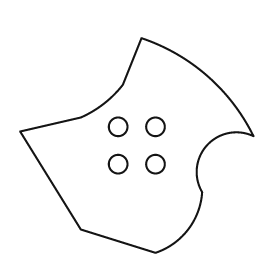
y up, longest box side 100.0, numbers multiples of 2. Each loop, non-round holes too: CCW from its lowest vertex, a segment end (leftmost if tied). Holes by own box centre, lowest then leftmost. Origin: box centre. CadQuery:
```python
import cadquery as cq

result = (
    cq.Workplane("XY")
    .moveTo(8.0, -46.0)
    .threePointArc((22.0, -36.0), (28.0, -20.0))
    .threePointArc((30.0, 0.0), (50.0, 4.0))
    .threePointArc((30.0, 30.0), (2.0, 46.0))
    .lineTo(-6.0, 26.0)
    .threePointArc((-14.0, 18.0), (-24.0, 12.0))
    .lineTo(-50.0, 6.0)
    .lineTo(-24.0, -36.0)
    .close()
    .moveTo(-8.0, -8.0)
    .circle(4.0)
    .moveTo(8.0, -8.0)
    .circle(4.0)
    .moveTo(-8.0, 8.0)
    .circle(4.0)
    .moveTo(8.0, 8.0)
    .circle(4.0)
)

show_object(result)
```